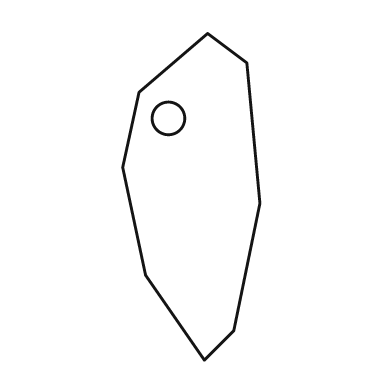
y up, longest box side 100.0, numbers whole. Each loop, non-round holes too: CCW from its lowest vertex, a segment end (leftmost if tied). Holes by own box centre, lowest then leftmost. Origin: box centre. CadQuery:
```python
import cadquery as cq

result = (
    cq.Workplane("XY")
    .moveTo(4.0, -50.0)
    .lineTo(13.0, -41.0)
    .lineTo(21.0, -2.0)
    .lineTo(17.0, 41.0)
    .lineTo(5.0, 50.0)
    .lineTo(-16.0, 32.0)
    .lineTo(-21.0, 9.0)
    .lineTo(-14.0, -24.0)
    .close()
    .moveTo(-7.0, 24.0)
    .circle(5.0)
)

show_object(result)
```